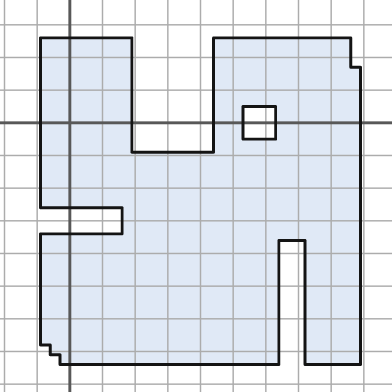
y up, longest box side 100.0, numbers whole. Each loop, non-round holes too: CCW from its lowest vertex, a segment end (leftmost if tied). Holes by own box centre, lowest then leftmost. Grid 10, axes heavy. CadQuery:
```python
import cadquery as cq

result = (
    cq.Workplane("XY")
    .moveTo(-3.0, -74.0)
    .lineTo(64.0, -74.0)
    .lineTo(64.0, -36.0)
    .lineTo(72.0, -36.0)
    .lineTo(72.0, -74.0)
    .lineTo(89.0, -74.0)
    .lineTo(89.0, 17.0)
    .lineTo(86.0, 17.0)
    .lineTo(86.0, 26.0)
    .lineTo(44.0, 26.0)
    .lineTo(44.0, -9.0)
    .lineTo(19.0, -9.0)
    .lineTo(19.0, 26.0)
    .lineTo(-9.0, 26.0)
    .lineTo(-9.0, -26.0)
    .lineTo(16.0, -26.0)
    .lineTo(16.0, -34.0)
    .lineTo(-9.0, -34.0)
    .lineTo(-9.0, -68.0)
    .lineTo(-6.0, -68.0)
    .lineTo(-6.0, -71.0)
    .lineTo(-3.0, -71.0)
    .close()
    .moveTo(53.0, -5.0)
    .lineTo(63.0, -5.0)
    .lineTo(63.0, 5.0)
    .lineTo(53.0, 5.0)
    .close()
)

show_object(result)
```